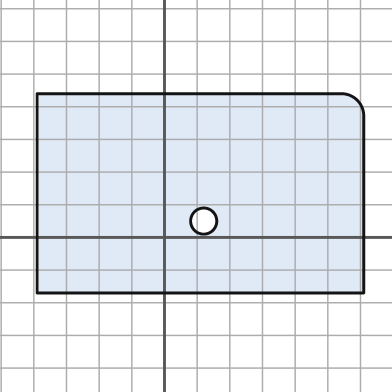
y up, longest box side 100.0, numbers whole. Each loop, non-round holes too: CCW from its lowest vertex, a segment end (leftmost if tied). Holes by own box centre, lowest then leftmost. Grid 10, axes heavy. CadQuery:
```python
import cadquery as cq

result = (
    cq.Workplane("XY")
    .moveTo(-39.0, -17.0)
    .lineTo(61.0, -17.0)
    .lineTo(61.0, 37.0)
    .threePointArc((59.0, 42.0), (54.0, 44.0))
    .lineTo(-39.0, 44.0)
    .close()
    .moveTo(12.0, 5.0)
    .circle(4.0)
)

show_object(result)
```